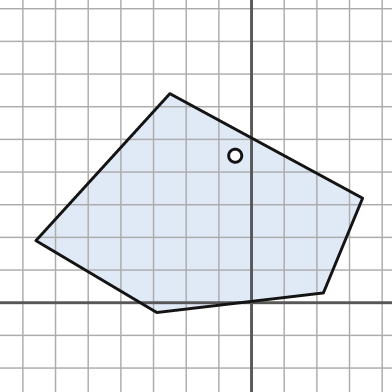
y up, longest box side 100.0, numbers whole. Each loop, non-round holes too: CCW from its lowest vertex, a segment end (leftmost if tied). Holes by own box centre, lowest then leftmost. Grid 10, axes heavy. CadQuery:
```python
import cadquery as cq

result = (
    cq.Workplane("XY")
    .moveTo(-29.0, -3.0)
    .lineTo(22.0, 3.0)
    .lineTo(34.0, 32.0)
    .lineTo(-25.0, 64.0)
    .lineTo(-66.0, 19.0)
    .close()
    .moveTo(-5.0, 45.0)
    .circle(2.0)
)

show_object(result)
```